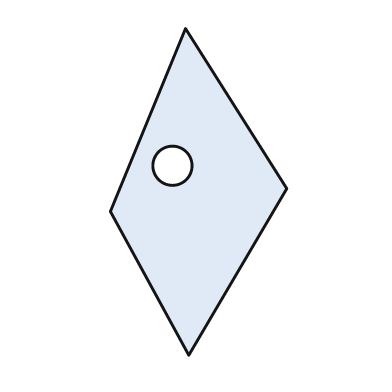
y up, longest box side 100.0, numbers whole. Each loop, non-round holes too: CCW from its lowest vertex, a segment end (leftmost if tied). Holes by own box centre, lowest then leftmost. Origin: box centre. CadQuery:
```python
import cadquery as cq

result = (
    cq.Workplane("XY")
    .moveTo(-3.0, -50.0)
    .lineTo(27.0, 1.0)
    .lineTo(-4.0, 50.0)
    .lineTo(-27.0, -6.0)
    .close()
    .moveTo(-8.0, 8.0)
    .circle(6.0)
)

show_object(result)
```